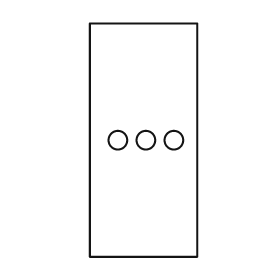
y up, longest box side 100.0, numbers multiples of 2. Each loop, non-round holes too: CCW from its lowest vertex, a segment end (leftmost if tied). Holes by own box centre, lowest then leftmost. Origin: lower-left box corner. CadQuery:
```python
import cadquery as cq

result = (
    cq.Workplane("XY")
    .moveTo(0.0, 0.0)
    .lineTo(46.0, 0.0)
    .lineTo(46.0, 100.0)
    .lineTo(0.0, 100.0)
    .close()
    .moveTo(12.0, 50.0)
    .circle(4.0)
    .moveTo(24.0, 50.0)
    .circle(4.0)
    .moveTo(36.0, 50.0)
    .circle(4.0)
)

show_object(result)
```